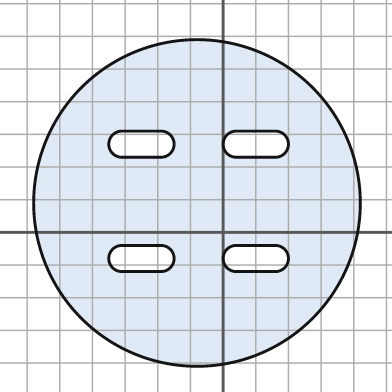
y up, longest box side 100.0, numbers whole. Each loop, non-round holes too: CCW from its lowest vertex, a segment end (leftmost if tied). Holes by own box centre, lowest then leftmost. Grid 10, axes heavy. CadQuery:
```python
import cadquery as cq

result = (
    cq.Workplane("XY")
    .moveTo(-8.0, 9.0)
    .circle(50.0)
    .moveTo(-31.0, -12.0)
    .lineTo(-19.0, -12.0)
    .threePointArc((-15.0, -8.0), (-19.0, -4.0))
    .lineTo(-31.0, -4.0)
    .threePointArc((-35.0, -8.0), (-31.0, -12.0))
    .close()
    .moveTo(4.0, -12.0)
    .lineTo(16.0, -12.0)
    .threePointArc((20.0, -8.0), (16.0, -4.0))
    .lineTo(4.0, -4.0)
    .threePointArc((0.0, -8.0), (4.0, -12.0))
    .close()
    .moveTo(-31.0, 23.0)
    .lineTo(-19.0, 23.0)
    .threePointArc((-15.0, 27.0), (-19.0, 31.0))
    .lineTo(-31.0, 31.0)
    .threePointArc((-35.0, 27.0), (-31.0, 23.0))
    .close()
    .moveTo(4.0, 23.0)
    .lineTo(16.0, 23.0)
    .threePointArc((20.0, 27.0), (16.0, 31.0))
    .lineTo(4.0, 31.0)
    .threePointArc((0.0, 27.0), (4.0, 23.0))
    .close()
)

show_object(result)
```